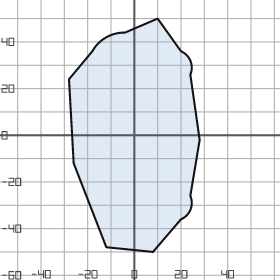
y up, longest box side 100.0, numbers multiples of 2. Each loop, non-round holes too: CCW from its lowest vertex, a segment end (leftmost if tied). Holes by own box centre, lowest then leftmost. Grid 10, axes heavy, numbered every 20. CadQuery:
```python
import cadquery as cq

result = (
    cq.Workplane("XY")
    .moveTo(8.0, -50.0)
    .lineTo(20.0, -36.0)
    .threePointArc((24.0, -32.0), (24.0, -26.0))
    .lineTo(28.0, -2.0)
    .lineTo(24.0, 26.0)
    .threePointArc((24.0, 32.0), (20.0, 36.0))
    .lineTo(10.0, 50.0)
    .lineTo(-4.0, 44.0)
    .threePointArc((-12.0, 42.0), (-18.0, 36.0))
    .lineTo(-28.0, 24.0)
    .lineTo(-26.0, -12.0)
    .lineTo(-12.0, -48.0)
    .close()
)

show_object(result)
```